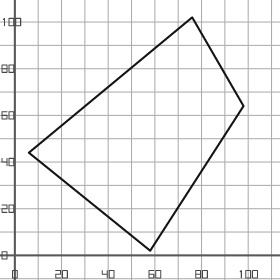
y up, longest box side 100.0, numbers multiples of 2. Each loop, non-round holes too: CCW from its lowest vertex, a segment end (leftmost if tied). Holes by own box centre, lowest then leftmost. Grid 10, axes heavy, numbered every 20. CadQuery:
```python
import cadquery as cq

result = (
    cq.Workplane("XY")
    .moveTo(58.0, 2.0)
    .lineTo(98.0, 64.0)
    .lineTo(76.0, 102.0)
    .lineTo(6.0, 44.0)
    .close()
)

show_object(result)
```